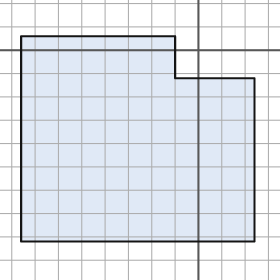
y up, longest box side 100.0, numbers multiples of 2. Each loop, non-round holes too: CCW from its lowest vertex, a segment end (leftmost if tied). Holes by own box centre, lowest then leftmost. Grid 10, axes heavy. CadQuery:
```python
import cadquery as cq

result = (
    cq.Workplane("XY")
    .moveTo(-76.0, -82.0)
    .lineTo(24.0, -82.0)
    .lineTo(24.0, -12.0)
    .lineTo(-10.0, -12.0)
    .lineTo(-10.0, 6.0)
    .lineTo(-76.0, 6.0)
    .close()
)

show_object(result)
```